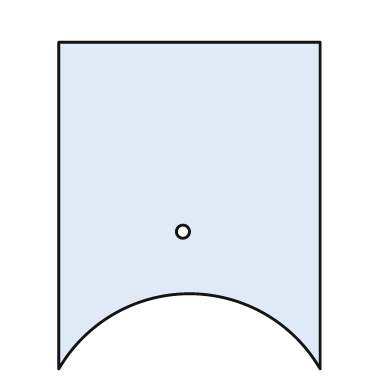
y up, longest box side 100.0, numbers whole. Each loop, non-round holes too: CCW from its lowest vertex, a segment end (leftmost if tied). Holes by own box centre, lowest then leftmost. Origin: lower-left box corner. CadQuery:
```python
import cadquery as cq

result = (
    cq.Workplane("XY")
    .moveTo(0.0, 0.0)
    .threePointArc((40.0, 23.0), (80.0, 0.0))
    .lineTo(80.0, 100.0)
    .lineTo(0.0, 100.0)
    .close()
    .moveTo(38.0, 42.0)
    .circle(2.0)
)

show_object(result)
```